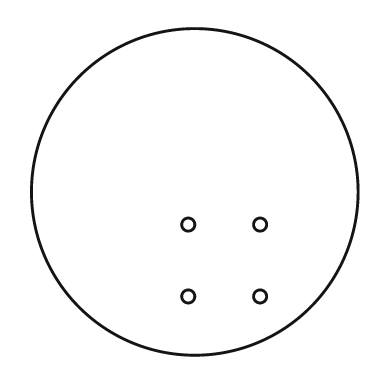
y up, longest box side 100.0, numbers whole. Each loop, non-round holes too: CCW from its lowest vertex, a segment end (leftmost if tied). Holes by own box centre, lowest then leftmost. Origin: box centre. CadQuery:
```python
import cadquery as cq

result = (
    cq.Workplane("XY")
    .moveTo(0.0, 0.0)
    .circle(50.0)
    .moveTo(-2.0, -32.0)
    .circle(2.0)
    .moveTo(20.0, -32.0)
    .circle(2.0)
    .moveTo(-2.0, -10.0)
    .circle(2.0)
    .moveTo(20.0, -10.0)
    .circle(2.0)
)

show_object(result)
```